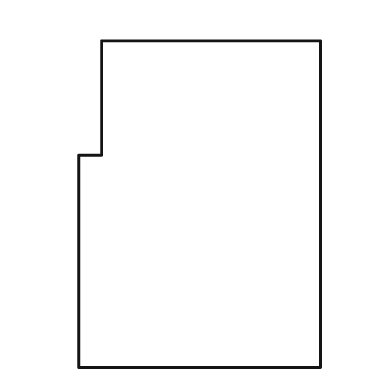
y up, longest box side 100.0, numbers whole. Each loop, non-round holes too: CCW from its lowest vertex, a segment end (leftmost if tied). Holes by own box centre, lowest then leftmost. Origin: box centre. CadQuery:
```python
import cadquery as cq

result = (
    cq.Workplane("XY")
    .moveTo(-37.0, -50.0)
    .lineTo(37.0, -50.0)
    .lineTo(37.0, 50.0)
    .lineTo(-30.0, 50.0)
    .lineTo(-30.0, 15.0)
    .lineTo(-37.0, 15.0)
    .close()
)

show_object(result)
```